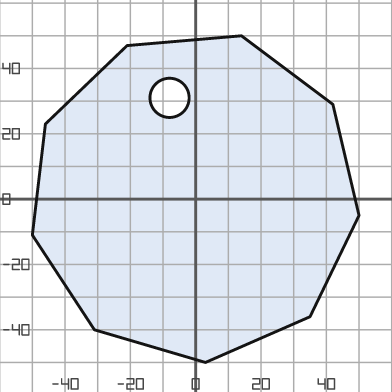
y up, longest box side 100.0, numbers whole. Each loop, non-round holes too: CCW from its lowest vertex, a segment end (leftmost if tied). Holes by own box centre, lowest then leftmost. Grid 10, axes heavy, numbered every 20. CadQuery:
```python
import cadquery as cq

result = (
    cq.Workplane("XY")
    .moveTo(3.0, -50.0)
    .lineTo(35.0, -36.0)
    .lineTo(50.0, -5.0)
    .lineTo(42.0, 29.0)
    .lineTo(14.0, 50.0)
    .lineTo(-21.0, 47.0)
    .lineTo(-46.0, 23.0)
    .lineTo(-50.0, -11.0)
    .lineTo(-31.0, -40.0)
    .close()
    .moveTo(-8.0, 31.0)
    .circle(6.0)
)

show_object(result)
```